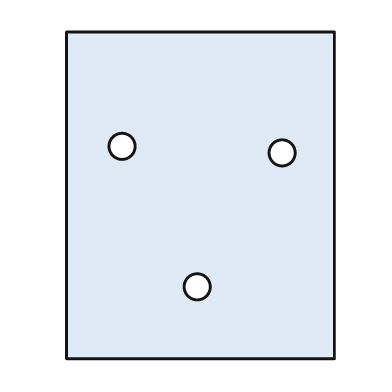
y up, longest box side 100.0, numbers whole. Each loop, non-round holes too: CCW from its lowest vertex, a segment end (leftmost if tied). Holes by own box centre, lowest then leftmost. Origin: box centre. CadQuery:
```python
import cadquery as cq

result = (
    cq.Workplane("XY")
    .moveTo(-41.0, -50.0)
    .lineTo(41.0, -50.0)
    .lineTo(41.0, 50.0)
    .lineTo(-41.0, 50.0)
    .close()
    .moveTo(-1.0, -28.0)
    .circle(4.0)
    .moveTo(25.0, 13.0)
    .circle(4.0)
    .moveTo(-24.0, 15.0)
    .circle(4.0)
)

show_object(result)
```